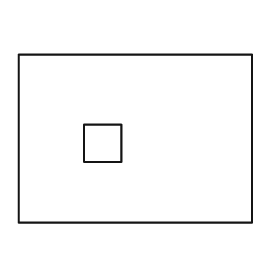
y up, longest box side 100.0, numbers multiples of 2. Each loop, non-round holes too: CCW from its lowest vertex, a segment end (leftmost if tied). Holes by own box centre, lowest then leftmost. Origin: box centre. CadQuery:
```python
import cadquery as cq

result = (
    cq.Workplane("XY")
    .moveTo(-50.0, -36.0)
    .lineTo(50.0, -36.0)
    .lineTo(50.0, 36.0)
    .lineTo(-50.0, 36.0)
    .close()
    .moveTo(-22.0, -10.0)
    .lineTo(-6.0, -10.0)
    .lineTo(-6.0, 6.0)
    .lineTo(-22.0, 6.0)
    .close()
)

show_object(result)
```